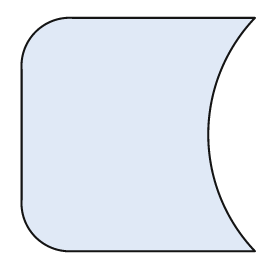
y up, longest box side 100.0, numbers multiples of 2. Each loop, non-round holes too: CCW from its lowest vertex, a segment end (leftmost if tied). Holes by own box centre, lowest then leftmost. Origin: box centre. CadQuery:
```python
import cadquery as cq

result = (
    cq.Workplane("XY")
    .moveTo(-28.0, -50.0)
    .lineTo(50.0, -50.0)
    .threePointArc((30.0, 0.0), (50.0, 50.0))
    .lineTo(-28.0, 50.0)
    .threePointArc((-44.0, 44.0), (-50.0, 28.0))
    .lineTo(-50.0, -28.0)
    .threePointArc((-44.0, -44.0), (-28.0, -50.0))
    .close()
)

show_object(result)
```